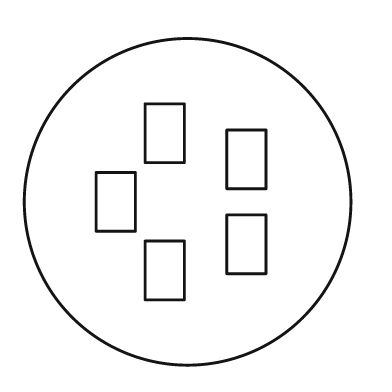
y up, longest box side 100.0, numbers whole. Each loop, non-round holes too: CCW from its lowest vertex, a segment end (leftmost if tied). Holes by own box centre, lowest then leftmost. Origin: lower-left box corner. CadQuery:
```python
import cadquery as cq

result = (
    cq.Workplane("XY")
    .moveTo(50.0, 50.0)
    .circle(50.0)
    .moveTo(37.0, 20.0)
    .lineTo(49.0, 20.0)
    .lineTo(49.0, 38.0)
    .lineTo(37.0, 38.0)
    .close()
    .moveTo(62.0, 28.0)
    .lineTo(74.0, 28.0)
    .lineTo(74.0, 46.0)
    .lineTo(62.0, 46.0)
    .close()
    .moveTo(22.0, 41.0)
    .lineTo(34.0, 41.0)
    .lineTo(34.0, 59.0)
    .lineTo(22.0, 59.0)
    .close()
    .moveTo(62.0, 54.0)
    .lineTo(74.0, 54.0)
    .lineTo(74.0, 72.0)
    .lineTo(62.0, 72.0)
    .close()
    .moveTo(37.0, 62.0)
    .lineTo(49.0, 62.0)
    .lineTo(49.0, 80.0)
    .lineTo(37.0, 80.0)
    .close()
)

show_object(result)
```